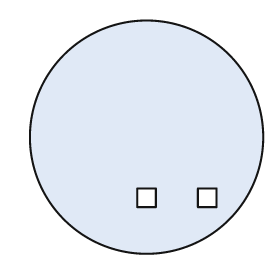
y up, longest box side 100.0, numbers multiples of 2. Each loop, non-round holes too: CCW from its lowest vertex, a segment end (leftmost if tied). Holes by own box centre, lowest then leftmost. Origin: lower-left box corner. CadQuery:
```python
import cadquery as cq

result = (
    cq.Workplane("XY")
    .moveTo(50.0, 50.0)
    .circle(50.0)
    .moveTo(46.0, 20.0)
    .lineTo(54.0, 20.0)
    .lineTo(54.0, 28.0)
    .lineTo(46.0, 28.0)
    .close()
    .moveTo(72.0, 20.0)
    .lineTo(80.0, 20.0)
    .lineTo(80.0, 28.0)
    .lineTo(72.0, 28.0)
    .close()
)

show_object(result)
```